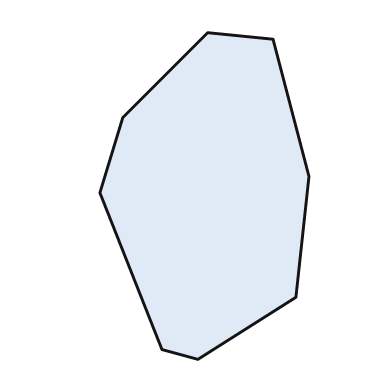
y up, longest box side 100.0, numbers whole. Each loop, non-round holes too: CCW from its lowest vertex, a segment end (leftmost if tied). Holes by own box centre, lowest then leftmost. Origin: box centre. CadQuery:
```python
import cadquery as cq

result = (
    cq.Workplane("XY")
    .moveTo(-2.0, -50.0)
    .lineTo(28.0, -31.0)
    .lineTo(32.0, 6.0)
    .lineTo(21.0, 48.0)
    .lineTo(1.0, 50.0)
    .lineTo(-25.0, 24.0)
    .lineTo(-32.0, 1.0)
    .lineTo(-13.0, -47.0)
    .close()
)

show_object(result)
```